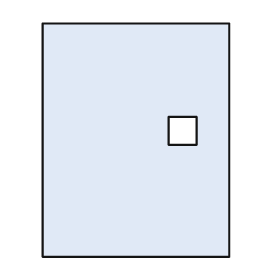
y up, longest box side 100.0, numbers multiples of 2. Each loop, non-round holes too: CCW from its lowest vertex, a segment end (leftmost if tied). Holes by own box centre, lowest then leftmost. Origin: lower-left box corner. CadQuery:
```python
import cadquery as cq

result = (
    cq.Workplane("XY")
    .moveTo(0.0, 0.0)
    .lineTo(80.0, 0.0)
    .lineTo(80.0, 100.0)
    .lineTo(0.0, 100.0)
    .close()
    .moveTo(54.0, 48.0)
    .lineTo(66.0, 48.0)
    .lineTo(66.0, 60.0)
    .lineTo(54.0, 60.0)
    .close()
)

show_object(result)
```